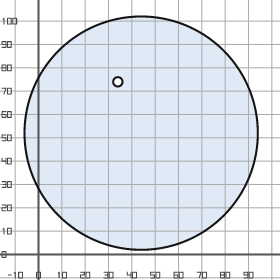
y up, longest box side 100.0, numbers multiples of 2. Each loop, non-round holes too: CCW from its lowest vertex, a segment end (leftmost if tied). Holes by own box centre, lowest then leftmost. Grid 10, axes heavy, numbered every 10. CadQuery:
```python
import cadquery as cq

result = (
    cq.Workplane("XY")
    .moveTo(44.0, 52.0)
    .circle(50.0)
    .moveTo(34.0, 74.0)
    .circle(2.0)
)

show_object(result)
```